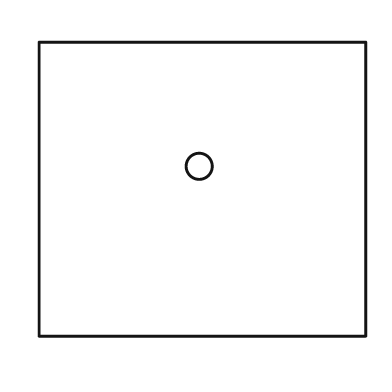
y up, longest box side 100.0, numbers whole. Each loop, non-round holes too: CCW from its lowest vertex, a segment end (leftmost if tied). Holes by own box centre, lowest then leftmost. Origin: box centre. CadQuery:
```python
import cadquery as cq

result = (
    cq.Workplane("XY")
    .moveTo(-50.0, -45.0)
    .lineTo(50.0, -45.0)
    .lineTo(50.0, 45.0)
    .lineTo(-50.0, 45.0)
    .close()
    .moveTo(-1.0, 7.0)
    .circle(4.0)
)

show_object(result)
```